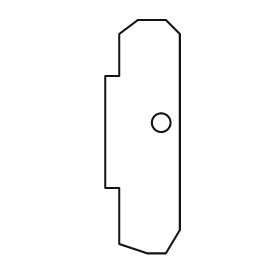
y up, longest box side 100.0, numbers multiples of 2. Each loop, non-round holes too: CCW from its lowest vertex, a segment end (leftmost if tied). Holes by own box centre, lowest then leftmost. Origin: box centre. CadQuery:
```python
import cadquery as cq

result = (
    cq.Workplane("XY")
    .moveTo(2.0, -50.0)
    .lineTo(10.0, -50.0)
    .lineTo(16.0, -40.0)
    .lineTo(16.0, 44.0)
    .lineTo(10.0, 50.0)
    .lineTo(-2.0, 50.0)
    .lineTo(-10.0, 44.0)
    .lineTo(-10.0, 26.0)
    .lineTo(-16.0, 26.0)
    .lineTo(-16.0, -22.0)
    .lineTo(-10.0, -22.0)
    .lineTo(-10.0, -46.0)
    .close()
    .moveTo(8.0, 6.0)
    .circle(4.0)
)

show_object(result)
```